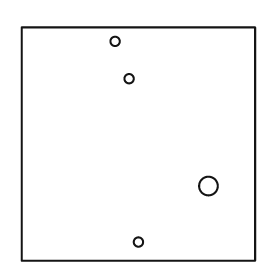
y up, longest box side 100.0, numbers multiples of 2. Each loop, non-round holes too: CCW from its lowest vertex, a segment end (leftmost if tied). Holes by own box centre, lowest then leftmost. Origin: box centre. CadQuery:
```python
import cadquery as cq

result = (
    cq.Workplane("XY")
    .moveTo(-50.0, -50.0)
    .lineTo(50.0, -50.0)
    .lineTo(50.0, 50.0)
    .lineTo(-50.0, 50.0)
    .close()
    .moveTo(0.0, -42.0)
    .circle(2.0)
    .moveTo(30.0, -18.0)
    .circle(4.0)
    .moveTo(-4.0, 28.0)
    .circle(2.0)
    .moveTo(-10.0, 44.0)
    .circle(2.0)
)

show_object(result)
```